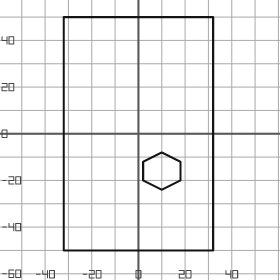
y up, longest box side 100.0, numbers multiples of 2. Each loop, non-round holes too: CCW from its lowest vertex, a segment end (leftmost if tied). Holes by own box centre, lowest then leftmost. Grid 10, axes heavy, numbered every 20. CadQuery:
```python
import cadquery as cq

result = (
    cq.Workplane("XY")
    .moveTo(-32.0, -50.0)
    .lineTo(32.0, -50.0)
    .lineTo(32.0, 50.0)
    .lineTo(-32.0, 50.0)
    .close()
    .moveTo(10.0, -24.0)
    .lineTo(18.0, -20.0)
    .lineTo(18.0, -12.0)
    .lineTo(10.0, -8.0)
    .lineTo(2.0, -12.0)
    .lineTo(2.0, -20.0)
    .close()
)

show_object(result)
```